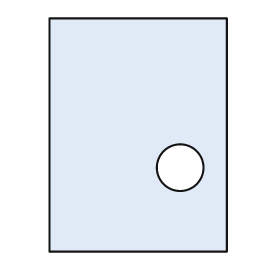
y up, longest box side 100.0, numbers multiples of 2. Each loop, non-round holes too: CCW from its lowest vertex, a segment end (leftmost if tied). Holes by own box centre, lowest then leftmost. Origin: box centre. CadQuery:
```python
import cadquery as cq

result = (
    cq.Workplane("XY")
    .moveTo(-38.0, -50.0)
    .lineTo(38.0, -50.0)
    .lineTo(38.0, 50.0)
    .lineTo(-38.0, 50.0)
    .close()
    .moveTo(18.0, -14.0)
    .circle(10.0)
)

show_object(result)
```